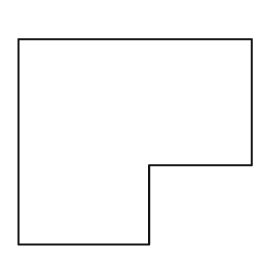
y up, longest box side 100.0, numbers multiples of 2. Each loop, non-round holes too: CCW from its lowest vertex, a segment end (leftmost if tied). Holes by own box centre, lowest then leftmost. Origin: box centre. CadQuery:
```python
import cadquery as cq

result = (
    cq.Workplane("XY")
    .moveTo(-50.0, -44.0)
    .lineTo(6.0, -44.0)
    .lineTo(6.0, -10.0)
    .lineTo(50.0, -10.0)
    .lineTo(50.0, 44.0)
    .lineTo(-50.0, 44.0)
    .close()
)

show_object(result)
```